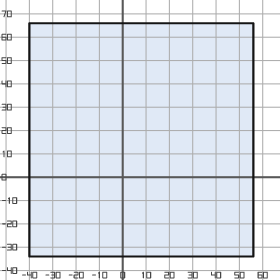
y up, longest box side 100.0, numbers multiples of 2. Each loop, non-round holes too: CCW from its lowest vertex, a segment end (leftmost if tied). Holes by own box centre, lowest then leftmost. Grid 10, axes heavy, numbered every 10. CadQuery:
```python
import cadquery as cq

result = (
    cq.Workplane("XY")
    .moveTo(-40.0, -34.0)
    .lineTo(56.0, -34.0)
    .lineTo(56.0, 66.0)
    .lineTo(-40.0, 66.0)
    .close()
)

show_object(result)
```